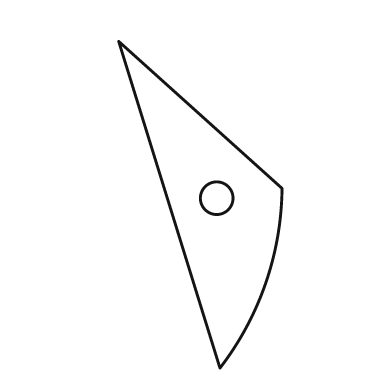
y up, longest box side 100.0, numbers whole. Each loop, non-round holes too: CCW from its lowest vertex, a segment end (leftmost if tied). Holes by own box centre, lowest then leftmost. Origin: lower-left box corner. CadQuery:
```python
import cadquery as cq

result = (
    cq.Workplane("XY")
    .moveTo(31.0, 0.0)
    .threePointArc((45.0, 26.0), (50.0, 55.0))
    .lineTo(0.0, 100.0)
    .close()
    .moveTo(30.0, 52.0)
    .circle(5.0)
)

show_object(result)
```